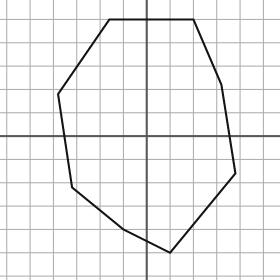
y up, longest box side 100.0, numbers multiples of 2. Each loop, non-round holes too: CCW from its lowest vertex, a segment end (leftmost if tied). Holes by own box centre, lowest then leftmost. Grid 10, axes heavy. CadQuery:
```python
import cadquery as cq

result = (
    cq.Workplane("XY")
    .moveTo(10.0, -50.0)
    .lineTo(38.0, -16.0)
    .lineTo(32.0, 22.0)
    .lineTo(20.0, 50.0)
    .lineTo(-16.0, 50.0)
    .lineTo(-38.0, 18.0)
    .lineTo(-32.0, -22.0)
    .lineTo(-10.0, -40.0)
    .close()
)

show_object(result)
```